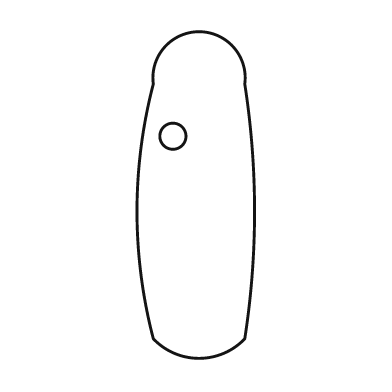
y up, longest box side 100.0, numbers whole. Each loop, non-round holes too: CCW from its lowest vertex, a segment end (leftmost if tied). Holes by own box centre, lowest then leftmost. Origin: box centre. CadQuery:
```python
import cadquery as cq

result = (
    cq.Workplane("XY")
    .moveTo(-13.0, -44.0)
    .threePointArc((1.0, -50.0), (15.0, -44.0))
    .threePointArc((18.0, -5.0), (15.0, 34.0))
    .threePointArc((1.0, 50.0), (-13.0, 34.0))
    .threePointArc((-18.0, -5.0), (-13.0, -44.0))
    .close()
    .moveTo(-7.0, 18.0)
    .circle(4.0)
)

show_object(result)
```